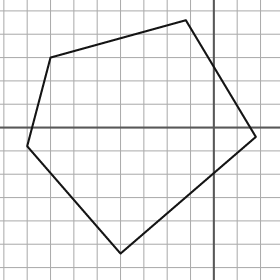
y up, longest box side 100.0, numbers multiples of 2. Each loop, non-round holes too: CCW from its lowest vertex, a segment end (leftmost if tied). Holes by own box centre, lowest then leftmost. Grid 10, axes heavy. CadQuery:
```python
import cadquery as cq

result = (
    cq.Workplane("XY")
    .moveTo(-40.0, -54.0)
    .lineTo(18.0, -4.0)
    .lineTo(-12.0, 46.0)
    .lineTo(-70.0, 30.0)
    .lineTo(-80.0, -8.0)
    .close()
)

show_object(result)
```